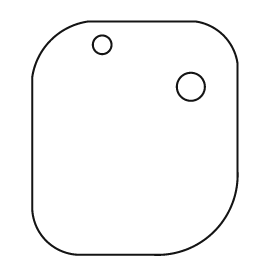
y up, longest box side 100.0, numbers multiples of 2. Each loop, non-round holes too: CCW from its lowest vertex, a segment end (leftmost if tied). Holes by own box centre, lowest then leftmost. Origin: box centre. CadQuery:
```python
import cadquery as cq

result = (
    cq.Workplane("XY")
    .moveTo(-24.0, -50.0)
    .lineTo(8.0, -50.0)
    .threePointArc((34.0, -40.0), (44.0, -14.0))
    .lineTo(44.0, 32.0)
    .threePointArc((38.0, 44.0), (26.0, 50.0))
    .lineTo(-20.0, 50.0)
    .threePointArc((-36.0, 42.0), (-44.0, 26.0))
    .lineTo(-44.0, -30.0)
    .threePointArc((-38.0, -44.0), (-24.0, -50.0))
    .close()
    .moveTo(24.0, 22.0)
    .circle(6.0)
    .moveTo(-14.0, 40.0)
    .circle(4.0)
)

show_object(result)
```